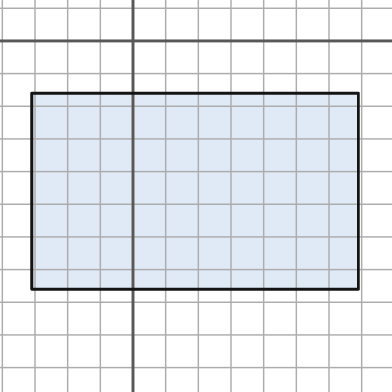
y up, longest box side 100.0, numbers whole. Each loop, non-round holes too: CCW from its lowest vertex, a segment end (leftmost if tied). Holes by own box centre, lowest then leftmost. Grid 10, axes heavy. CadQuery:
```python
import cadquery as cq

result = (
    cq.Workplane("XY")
    .moveTo(-31.0, -76.0)
    .lineTo(69.0, -76.0)
    .lineTo(69.0, -16.0)
    .lineTo(-31.0, -16.0)
    .close()
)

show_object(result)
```